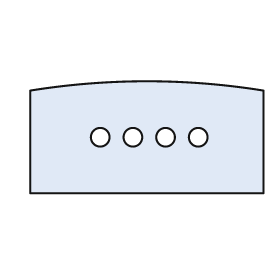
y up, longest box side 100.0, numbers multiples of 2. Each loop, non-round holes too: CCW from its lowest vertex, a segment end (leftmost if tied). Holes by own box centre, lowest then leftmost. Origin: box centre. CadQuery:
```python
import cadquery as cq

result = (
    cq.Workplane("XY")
    .moveTo(-50.0, -24.0)
    .lineTo(50.0, -24.0)
    .lineTo(50.0, 20.0)
    .threePointArc((0.0, 24.0), (-50.0, 20.0))
    .close()
    .moveTo(-20.0, 0.0)
    .circle(4.0)
    .moveTo(-6.0, 0.0)
    .circle(4.0)
    .moveTo(8.0, 0.0)
    .circle(4.0)
    .moveTo(22.0, 0.0)
    .circle(4.0)
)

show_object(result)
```